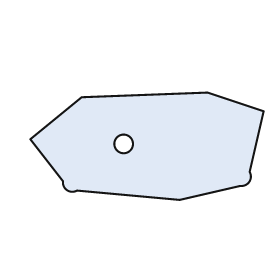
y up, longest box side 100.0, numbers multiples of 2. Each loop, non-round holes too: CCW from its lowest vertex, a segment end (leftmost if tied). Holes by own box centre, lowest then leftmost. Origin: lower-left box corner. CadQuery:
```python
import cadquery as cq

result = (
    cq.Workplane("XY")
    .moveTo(64.0, 0.0)
    .lineTo(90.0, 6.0)
    .threePointArc((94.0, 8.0), (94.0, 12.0))
    .lineTo(100.0, 38.0)
    .lineTo(76.0, 46.0)
    .lineTo(22.0, 44.0)
    .lineTo(0.0, 26.0)
    .lineTo(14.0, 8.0)
    .threePointArc((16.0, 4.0), (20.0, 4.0))
    .close()
    .moveTo(40.0, 24.0)
    .circle(4.0)
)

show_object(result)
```